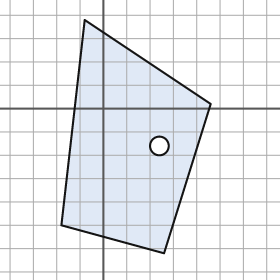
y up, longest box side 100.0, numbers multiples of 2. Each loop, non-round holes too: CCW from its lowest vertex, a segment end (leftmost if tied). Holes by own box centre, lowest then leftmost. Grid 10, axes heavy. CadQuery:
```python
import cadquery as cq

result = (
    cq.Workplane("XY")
    .moveTo(26.0, -62.0)
    .lineTo(46.0, 2.0)
    .lineTo(-8.0, 38.0)
    .lineTo(-18.0, -50.0)
    .close()
    .moveTo(24.0, -16.0)
    .circle(4.0)
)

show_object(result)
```